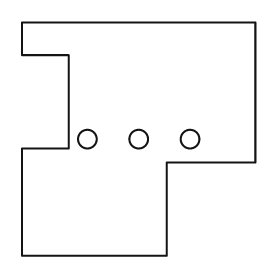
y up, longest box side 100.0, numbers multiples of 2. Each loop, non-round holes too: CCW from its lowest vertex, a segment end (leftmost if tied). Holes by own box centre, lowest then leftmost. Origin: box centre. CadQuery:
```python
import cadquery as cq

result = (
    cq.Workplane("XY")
    .moveTo(-50.0, -50.0)
    .lineTo(12.0, -50.0)
    .lineTo(12.0, -10.0)
    .lineTo(50.0, -10.0)
    .lineTo(50.0, 50.0)
    .lineTo(-50.0, 50.0)
    .lineTo(-50.0, 36.0)
    .lineTo(-30.0, 36.0)
    .lineTo(-30.0, -4.0)
    .lineTo(-50.0, -4.0)
    .close()
    .moveTo(-22.0, 0.0)
    .circle(4.0)
    .moveTo(0.0, 0.0)
    .circle(4.0)
    .moveTo(22.0, 0.0)
    .circle(4.0)
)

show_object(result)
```